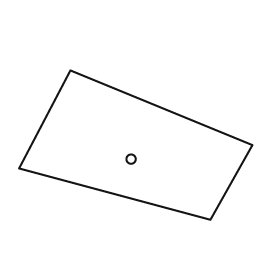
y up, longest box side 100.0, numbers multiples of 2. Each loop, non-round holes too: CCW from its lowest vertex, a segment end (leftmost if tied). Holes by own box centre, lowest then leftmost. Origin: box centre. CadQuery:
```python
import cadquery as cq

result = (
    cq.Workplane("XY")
    .moveTo(32.0, -32.0)
    .lineTo(50.0, 0.0)
    .lineTo(-28.0, 32.0)
    .lineTo(-50.0, -10.0)
    .close()
    .moveTo(-2.0, -6.0)
    .circle(2.0)
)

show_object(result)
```